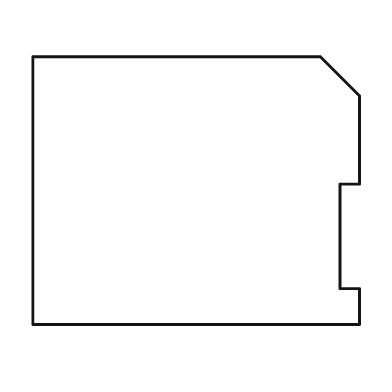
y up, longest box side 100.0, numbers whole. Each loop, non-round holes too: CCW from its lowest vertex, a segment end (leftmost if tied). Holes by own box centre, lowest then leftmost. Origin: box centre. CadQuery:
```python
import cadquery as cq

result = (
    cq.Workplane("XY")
    .moveTo(-50.0, -41.0)
    .lineTo(50.0, -41.0)
    .lineTo(50.0, -30.0)
    .lineTo(44.0, -30.0)
    .lineTo(44.0, 2.0)
    .lineTo(50.0, 2.0)
    .lineTo(50.0, 29.0)
    .lineTo(38.0, 41.0)
    .lineTo(-50.0, 41.0)
    .close()
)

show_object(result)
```